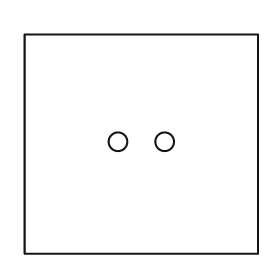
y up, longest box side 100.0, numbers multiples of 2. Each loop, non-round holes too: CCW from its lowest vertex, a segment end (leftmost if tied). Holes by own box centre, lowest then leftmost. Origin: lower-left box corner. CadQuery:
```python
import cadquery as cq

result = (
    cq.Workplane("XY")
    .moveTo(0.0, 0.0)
    .lineTo(100.0, 0.0)
    .lineTo(100.0, 94.0)
    .lineTo(0.0, 94.0)
    .close()
    .moveTo(40.0, 48.0)
    .circle(4.0)
    .moveTo(60.0, 48.0)
    .circle(4.0)
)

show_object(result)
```